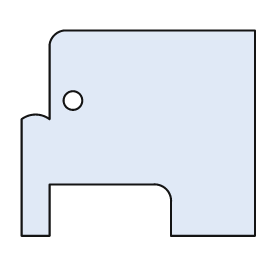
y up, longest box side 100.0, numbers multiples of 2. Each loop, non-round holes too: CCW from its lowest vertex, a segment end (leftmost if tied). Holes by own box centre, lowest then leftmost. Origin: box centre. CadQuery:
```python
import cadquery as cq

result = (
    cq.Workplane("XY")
    .moveTo(-50.0, -44.0)
    .lineTo(-38.0, -44.0)
    .lineTo(-38.0, -22.0)
    .lineTo(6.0, -22.0)
    .threePointArc((12.0, -24.0), (14.0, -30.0))
    .lineTo(14.0, -44.0)
    .lineTo(50.0, -44.0)
    .lineTo(50.0, 44.0)
    .lineTo(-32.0, 44.0)
    .threePointArc((-36.0, 42.0), (-38.0, 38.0))
    .lineTo(-38.0, 6.0)
    .threePointArc((-44.0, 8.0), (-50.0, 6.0))
    .close()
    .moveTo(-28.0, 14.0)
    .circle(4.0)
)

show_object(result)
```